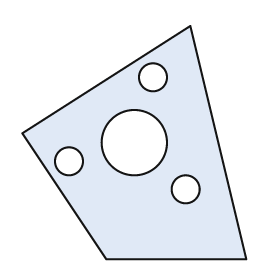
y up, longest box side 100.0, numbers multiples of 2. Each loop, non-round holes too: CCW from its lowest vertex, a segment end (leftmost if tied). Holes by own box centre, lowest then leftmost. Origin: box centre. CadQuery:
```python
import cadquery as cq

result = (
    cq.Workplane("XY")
    .moveTo(-12.0, -50.0)
    .lineTo(48.0, -50.0)
    .lineTo(24.0, 50.0)
    .lineTo(-48.0, 4.0)
    .close()
    .moveTo(22.0, -20.0)
    .circle(6.0)
    .moveTo(-28.0, -8.0)
    .circle(6.0)
    .moveTo(0.0, 0.0)
    .circle(14.0)
    .moveTo(8.0, 28.0)
    .circle(6.0)
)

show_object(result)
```